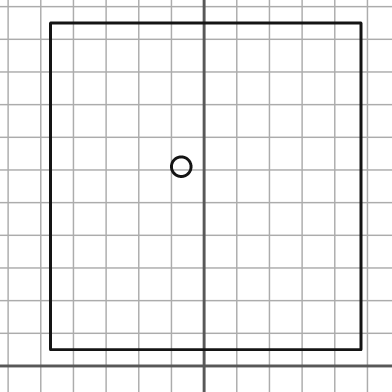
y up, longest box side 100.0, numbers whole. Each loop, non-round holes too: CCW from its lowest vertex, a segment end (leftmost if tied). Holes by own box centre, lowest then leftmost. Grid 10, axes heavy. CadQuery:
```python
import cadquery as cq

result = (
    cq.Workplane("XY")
    .moveTo(-47.0, 5.0)
    .lineTo(48.0, 5.0)
    .lineTo(48.0, 105.0)
    .lineTo(-47.0, 105.0)
    .close()
    .moveTo(-7.0, 61.0)
    .circle(3.0)
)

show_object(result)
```